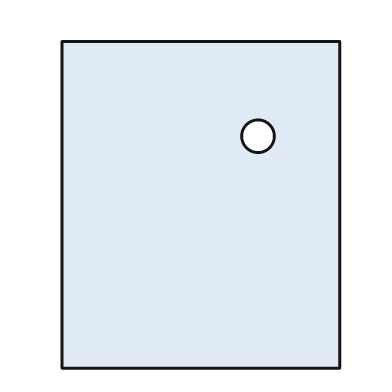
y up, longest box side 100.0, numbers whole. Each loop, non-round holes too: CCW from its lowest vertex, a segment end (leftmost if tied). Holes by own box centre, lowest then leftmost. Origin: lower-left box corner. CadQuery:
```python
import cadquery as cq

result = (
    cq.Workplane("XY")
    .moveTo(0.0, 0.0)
    .lineTo(85.0, 0.0)
    .lineTo(85.0, 100.0)
    .lineTo(0.0, 100.0)
    .close()
    .moveTo(60.0, 71.0)
    .circle(5.0)
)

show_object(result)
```